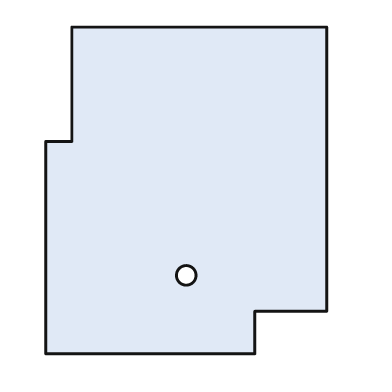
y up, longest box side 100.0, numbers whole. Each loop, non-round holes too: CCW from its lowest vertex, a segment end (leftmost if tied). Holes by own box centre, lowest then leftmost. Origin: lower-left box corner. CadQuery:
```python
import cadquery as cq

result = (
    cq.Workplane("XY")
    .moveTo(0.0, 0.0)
    .lineTo(64.0, 0.0)
    .lineTo(64.0, 13.0)
    .lineTo(86.0, 13.0)
    .lineTo(86.0, 100.0)
    .lineTo(8.0, 100.0)
    .lineTo(8.0, 65.0)
    .lineTo(0.0, 65.0)
    .close()
    .moveTo(43.0, 24.0)
    .circle(3.0)
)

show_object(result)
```